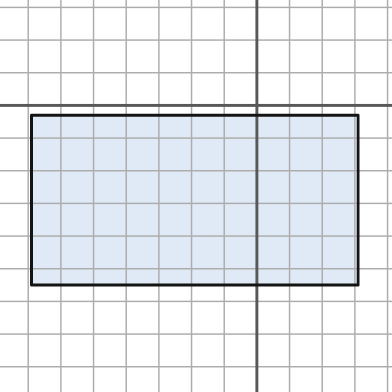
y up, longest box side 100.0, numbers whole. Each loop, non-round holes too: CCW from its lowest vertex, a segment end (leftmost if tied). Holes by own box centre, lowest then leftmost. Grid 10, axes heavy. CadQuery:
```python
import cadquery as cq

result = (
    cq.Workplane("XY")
    .moveTo(-69.0, -55.0)
    .lineTo(31.0, -55.0)
    .lineTo(31.0, -3.0)
    .lineTo(-69.0, -3.0)
    .close()
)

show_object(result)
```